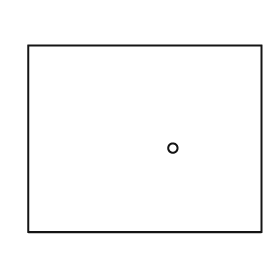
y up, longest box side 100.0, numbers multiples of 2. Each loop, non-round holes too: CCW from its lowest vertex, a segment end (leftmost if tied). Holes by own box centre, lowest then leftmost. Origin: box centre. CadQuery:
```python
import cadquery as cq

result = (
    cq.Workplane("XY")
    .moveTo(-50.0, -40.0)
    .lineTo(50.0, -40.0)
    .lineTo(50.0, 40.0)
    .lineTo(-50.0, 40.0)
    .close()
    .moveTo(12.0, -4.0)
    .circle(2.0)
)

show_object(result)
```